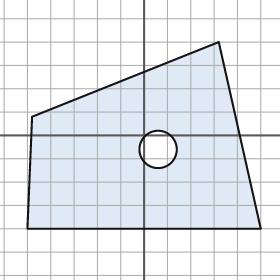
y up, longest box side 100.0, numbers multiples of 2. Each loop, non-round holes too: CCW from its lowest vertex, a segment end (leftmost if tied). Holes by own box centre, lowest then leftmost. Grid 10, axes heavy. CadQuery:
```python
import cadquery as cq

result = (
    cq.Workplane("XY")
    .moveTo(-50.0, -40.0)
    .lineTo(50.0, -40.0)
    .lineTo(32.0, 40.0)
    .lineTo(-48.0, 8.0)
    .close()
    .moveTo(6.0, -6.0)
    .circle(8.0)
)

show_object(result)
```